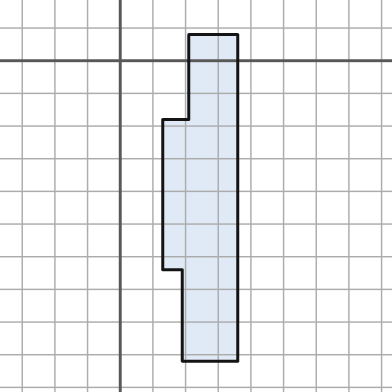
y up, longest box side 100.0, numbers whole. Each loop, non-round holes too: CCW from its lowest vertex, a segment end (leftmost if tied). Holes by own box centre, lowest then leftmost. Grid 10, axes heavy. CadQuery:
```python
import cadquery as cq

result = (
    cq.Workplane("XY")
    .moveTo(19.0, -92.0)
    .lineTo(36.0, -92.0)
    .lineTo(36.0, 8.0)
    .lineTo(21.0, 8.0)
    .lineTo(21.0, -18.0)
    .lineTo(13.0, -18.0)
    .lineTo(13.0, -64.0)
    .lineTo(19.0, -64.0)
    .close()
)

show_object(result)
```